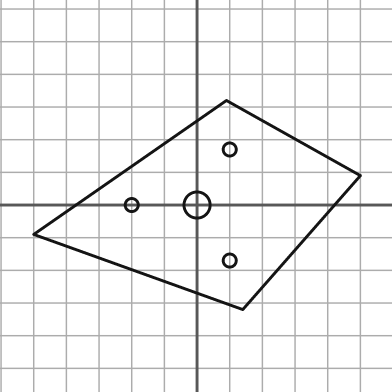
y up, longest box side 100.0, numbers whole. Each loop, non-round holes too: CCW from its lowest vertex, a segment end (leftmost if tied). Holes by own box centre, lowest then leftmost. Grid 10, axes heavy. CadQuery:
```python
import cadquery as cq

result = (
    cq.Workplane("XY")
    .moveTo(14.0, -32.0)
    .lineTo(50.0, 9.0)
    .lineTo(9.0, 32.0)
    .lineTo(-50.0, -9.0)
    .close()
    .moveTo(10.0, -17.0)
    .circle(2.0)
    .moveTo(-20.0, 0.0)
    .circle(2.0)
    .moveTo(0.0, 0.0)
    .circle(4.0)
    .moveTo(10.0, 17.0)
    .circle(2.0)
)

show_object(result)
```